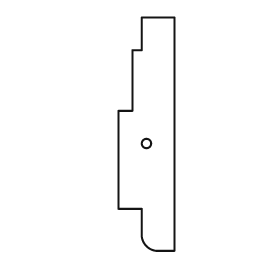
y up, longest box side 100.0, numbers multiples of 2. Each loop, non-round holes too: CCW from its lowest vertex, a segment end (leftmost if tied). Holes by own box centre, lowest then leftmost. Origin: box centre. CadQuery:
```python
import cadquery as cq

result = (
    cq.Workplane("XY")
    .moveTo(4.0, -50.0)
    .lineTo(12.0, -50.0)
    .lineTo(12.0, 50.0)
    .lineTo(-2.0, 50.0)
    .lineTo(-2.0, 36.0)
    .lineTo(-6.0, 36.0)
    .lineTo(-6.0, 10.0)
    .lineTo(-12.0, 10.0)
    .lineTo(-12.0, -32.0)
    .lineTo(-2.0, -32.0)
    .lineTo(-2.0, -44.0)
    .threePointArc((0.0, -48.0), (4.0, -50.0))
    .close()
    .moveTo(0.0, -4.0)
    .circle(2.0)
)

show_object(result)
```